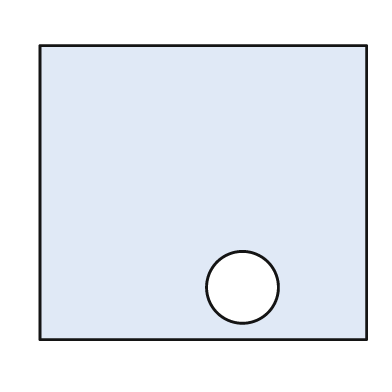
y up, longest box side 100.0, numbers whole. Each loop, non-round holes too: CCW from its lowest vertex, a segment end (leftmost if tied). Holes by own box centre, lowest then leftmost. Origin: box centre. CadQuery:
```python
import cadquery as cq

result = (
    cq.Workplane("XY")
    .moveTo(-50.0, -45.0)
    .lineTo(50.0, -45.0)
    .lineTo(50.0, 45.0)
    .lineTo(-50.0, 45.0)
    .close()
    .moveTo(12.0, -29.0)
    .circle(11.0)
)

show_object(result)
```